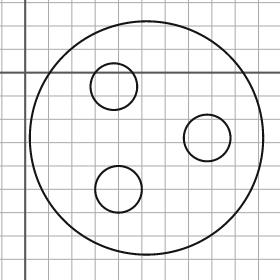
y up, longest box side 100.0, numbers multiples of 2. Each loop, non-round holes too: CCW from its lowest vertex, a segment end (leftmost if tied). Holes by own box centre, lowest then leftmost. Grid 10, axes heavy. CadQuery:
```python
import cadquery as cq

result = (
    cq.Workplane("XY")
    .moveTo(52.0, -28.0)
    .circle(50.0)
    .moveTo(40.0, -50.0)
    .circle(10.0)
    .moveTo(78.0, -28.0)
    .circle(10.0)
    .moveTo(38.0, -6.0)
    .circle(10.0)
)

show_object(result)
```